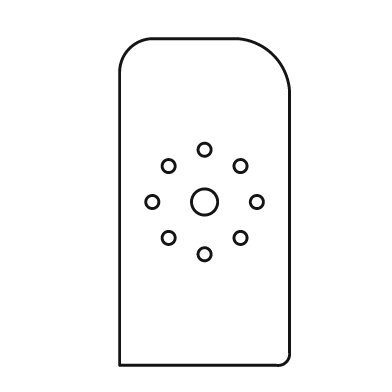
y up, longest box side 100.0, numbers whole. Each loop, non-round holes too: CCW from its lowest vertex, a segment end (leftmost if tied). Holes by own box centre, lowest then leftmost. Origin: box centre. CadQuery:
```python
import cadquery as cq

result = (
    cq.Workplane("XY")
    .moveTo(-26.0, -50.0)
    .lineTo(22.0, -50.0)
    .threePointArc((25.0, -49.0), (26.0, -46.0))
    .lineTo(26.0, 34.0)
    .threePointArc((21.0, 45.0), (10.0, 50.0))
    .lineTo(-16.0, 50.0)
    .threePointArc((-23.0, 47.0), (-26.0, 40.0))
    .close()
    .moveTo(0.0, -16.0)
    .circle(2.0)
    .moveTo(-11.0, -11.0)
    .circle(2.0)
    .moveTo(11.0, -11.0)
    .circle(2.0)
    .moveTo(-16.0, 0.0)
    .circle(2.0)
    .moveTo(0.0, 0.0)
    .circle(4.0)
    .moveTo(16.0, 0.0)
    .circle(2.0)
    .moveTo(-11.0, 11.0)
    .circle(2.0)
    .moveTo(11.0, 11.0)
    .circle(2.0)
    .moveTo(0.0, 16.0)
    .circle(2.0)
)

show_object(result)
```